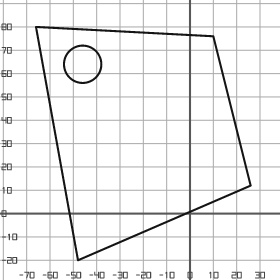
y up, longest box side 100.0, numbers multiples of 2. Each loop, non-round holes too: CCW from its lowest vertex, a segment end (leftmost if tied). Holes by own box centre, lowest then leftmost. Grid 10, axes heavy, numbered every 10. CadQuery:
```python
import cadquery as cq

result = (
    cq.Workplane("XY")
    .moveTo(-48.0, -20.0)
    .lineTo(26.0, 12.0)
    .lineTo(10.0, 76.0)
    .lineTo(-66.0, 80.0)
    .close()
    .moveTo(-46.0, 64.0)
    .circle(8.0)
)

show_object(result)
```